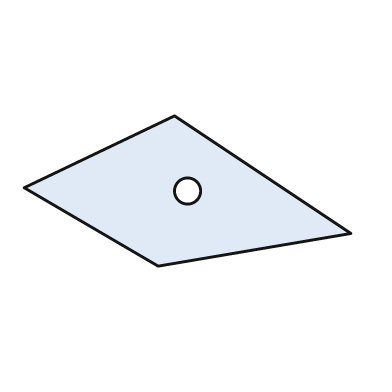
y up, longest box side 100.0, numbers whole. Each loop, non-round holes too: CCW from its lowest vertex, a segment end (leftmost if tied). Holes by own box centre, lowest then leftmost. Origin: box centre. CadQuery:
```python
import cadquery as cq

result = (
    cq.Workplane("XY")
    .moveTo(-9.0, -23.0)
    .lineTo(50.0, -13.0)
    .lineTo(-4.0, 23.0)
    .lineTo(-50.0, 1.0)
    .close()
    .moveTo(0.0, 0.0)
    .circle(4.0)
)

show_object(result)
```